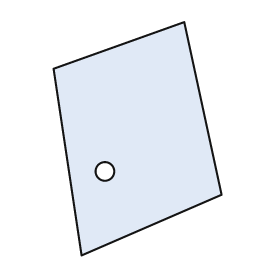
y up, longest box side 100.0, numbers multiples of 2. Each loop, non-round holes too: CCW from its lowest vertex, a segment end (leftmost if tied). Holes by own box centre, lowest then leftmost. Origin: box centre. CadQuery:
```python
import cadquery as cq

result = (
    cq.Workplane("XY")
    .moveTo(-24.0, -50.0)
    .lineTo(36.0, -24.0)
    .lineTo(20.0, 50.0)
    .lineTo(-36.0, 30.0)
    .close()
    .moveTo(-14.0, -14.0)
    .circle(4.0)
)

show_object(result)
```